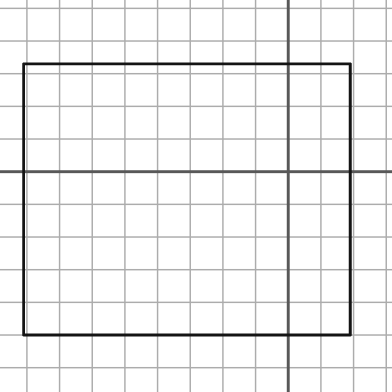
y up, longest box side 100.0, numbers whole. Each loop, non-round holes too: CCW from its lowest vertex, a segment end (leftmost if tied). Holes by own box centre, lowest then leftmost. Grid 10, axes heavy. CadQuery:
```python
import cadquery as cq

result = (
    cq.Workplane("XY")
    .moveTo(-81.0, -50.0)
    .lineTo(19.0, -50.0)
    .lineTo(19.0, 33.0)
    .lineTo(-81.0, 33.0)
    .close()
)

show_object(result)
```